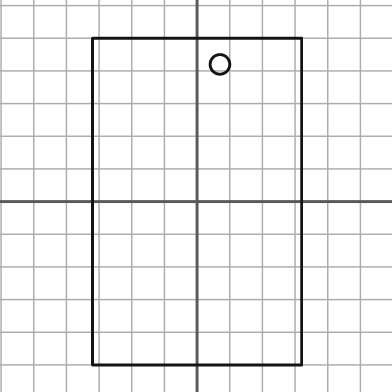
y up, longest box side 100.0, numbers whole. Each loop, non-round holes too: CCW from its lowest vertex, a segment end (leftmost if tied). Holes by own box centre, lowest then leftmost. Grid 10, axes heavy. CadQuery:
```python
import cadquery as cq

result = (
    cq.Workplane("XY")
    .moveTo(-32.0, -50.0)
    .lineTo(32.0, -50.0)
    .lineTo(32.0, 50.0)
    .lineTo(-32.0, 50.0)
    .close()
    .moveTo(7.0, 42.0)
    .circle(3.0)
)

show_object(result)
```